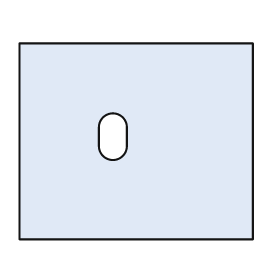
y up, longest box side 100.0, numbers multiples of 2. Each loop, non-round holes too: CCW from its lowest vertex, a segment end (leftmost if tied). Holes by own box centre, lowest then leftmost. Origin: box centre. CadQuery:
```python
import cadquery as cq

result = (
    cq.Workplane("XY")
    .moveTo(-50.0, -42.0)
    .lineTo(50.0, -42.0)
    .lineTo(50.0, 42.0)
    .lineTo(-50.0, 42.0)
    .close()
    .moveTo(-16.0, -2.0)
    .threePointArc((-10.0, -8.0), (-4.0, -2.0))
    .lineTo(-4.0, 6.0)
    .threePointArc((-10.0, 12.0), (-16.0, 6.0))
    .close()
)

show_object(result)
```